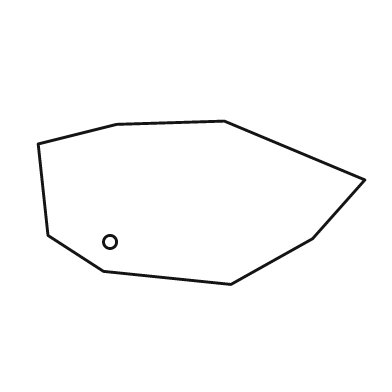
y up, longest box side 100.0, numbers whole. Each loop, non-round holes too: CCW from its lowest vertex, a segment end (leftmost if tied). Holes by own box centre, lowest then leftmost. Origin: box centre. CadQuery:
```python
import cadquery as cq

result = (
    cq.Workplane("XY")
    .moveTo(9.0, -25.0)
    .lineTo(34.0, -11.0)
    .lineTo(50.0, 7.0)
    .lineTo(7.0, 25.0)
    .lineTo(-26.0, 24.0)
    .lineTo(-50.0, 18.0)
    .lineTo(-47.0, -10.0)
    .lineTo(-30.0, -21.0)
    .close()
    .moveTo(-28.0, -12.0)
    .circle(2.0)
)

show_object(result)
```